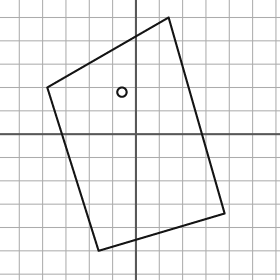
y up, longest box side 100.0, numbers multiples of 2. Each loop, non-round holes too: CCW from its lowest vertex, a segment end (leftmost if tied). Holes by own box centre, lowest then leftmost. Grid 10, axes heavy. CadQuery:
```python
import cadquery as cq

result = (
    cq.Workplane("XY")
    .moveTo(-16.0, -50.0)
    .lineTo(38.0, -34.0)
    .lineTo(14.0, 50.0)
    .lineTo(-38.0, 20.0)
    .close()
    .moveTo(-6.0, 18.0)
    .circle(2.0)
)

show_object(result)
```